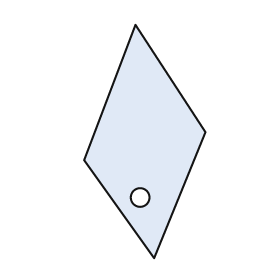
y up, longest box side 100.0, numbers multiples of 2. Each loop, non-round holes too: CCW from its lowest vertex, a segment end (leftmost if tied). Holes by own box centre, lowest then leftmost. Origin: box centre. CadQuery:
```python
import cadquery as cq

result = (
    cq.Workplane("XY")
    .moveTo(4.0, -50.0)
    .lineTo(26.0, 4.0)
    .lineTo(-4.0, 50.0)
    .lineTo(-26.0, -8.0)
    .close()
    .moveTo(-2.0, -24.0)
    .circle(4.0)
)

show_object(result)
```